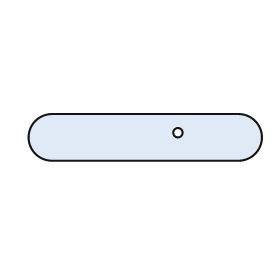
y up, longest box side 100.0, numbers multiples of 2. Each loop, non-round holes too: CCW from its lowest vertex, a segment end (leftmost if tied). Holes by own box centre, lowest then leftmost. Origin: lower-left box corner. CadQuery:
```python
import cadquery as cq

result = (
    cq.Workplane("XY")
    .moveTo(10.0, 0.0)
    .lineTo(90.0, 0.0)
    .threePointArc((100.0, 10.0), (90.0, 20.0))
    .lineTo(10.0, 20.0)
    .threePointArc((0.0, 10.0), (10.0, 0.0))
    .close()
    .moveTo(64.0, 12.0)
    .circle(2.0)
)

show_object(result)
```